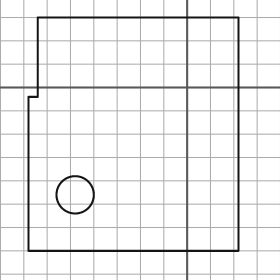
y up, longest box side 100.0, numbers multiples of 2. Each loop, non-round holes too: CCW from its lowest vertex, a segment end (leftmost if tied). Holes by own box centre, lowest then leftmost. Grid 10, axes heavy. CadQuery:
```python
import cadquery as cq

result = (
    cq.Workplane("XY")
    .moveTo(-68.0, -70.0)
    .lineTo(22.0, -70.0)
    .lineTo(22.0, 30.0)
    .lineTo(-64.0, 30.0)
    .lineTo(-64.0, -4.0)
    .lineTo(-68.0, -4.0)
    .close()
    .moveTo(-48.0, -46.0)
    .circle(8.0)
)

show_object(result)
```